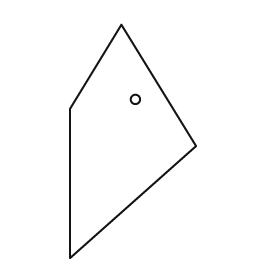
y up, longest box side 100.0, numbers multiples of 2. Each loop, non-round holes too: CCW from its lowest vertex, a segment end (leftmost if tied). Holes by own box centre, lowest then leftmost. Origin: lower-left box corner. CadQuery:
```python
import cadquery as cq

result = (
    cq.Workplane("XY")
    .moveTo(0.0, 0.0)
    .lineTo(54.0, 48.0)
    .lineTo(22.0, 100.0)
    .lineTo(0.0, 64.0)
    .close()
    .moveTo(28.0, 68.0)
    .circle(2.0)
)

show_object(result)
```